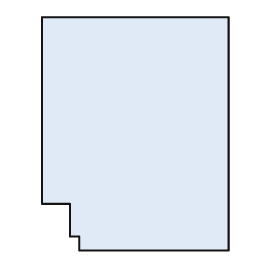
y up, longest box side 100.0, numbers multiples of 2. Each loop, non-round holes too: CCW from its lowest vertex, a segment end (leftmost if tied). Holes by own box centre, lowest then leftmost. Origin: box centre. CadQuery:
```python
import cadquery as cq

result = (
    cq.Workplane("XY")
    .moveTo(-24.0, -50.0)
    .lineTo(40.0, -50.0)
    .lineTo(40.0, 50.0)
    .lineTo(-40.0, 50.0)
    .lineTo(-40.0, -30.0)
    .lineTo(-28.0, -30.0)
    .lineTo(-28.0, -44.0)
    .lineTo(-24.0, -44.0)
    .close()
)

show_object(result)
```